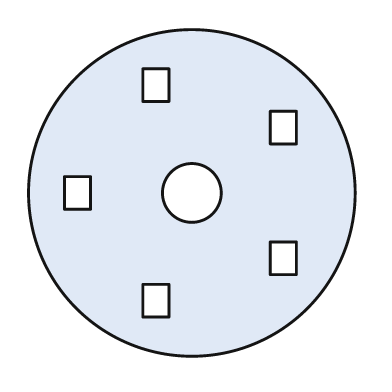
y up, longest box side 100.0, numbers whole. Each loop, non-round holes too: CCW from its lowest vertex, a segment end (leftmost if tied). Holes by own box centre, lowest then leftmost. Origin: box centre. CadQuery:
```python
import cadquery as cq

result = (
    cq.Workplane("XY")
    .moveTo(0.0, 0.0)
    .circle(50.0)
    .moveTo(-15.0, -38.0)
    .lineTo(-7.0, -38.0)
    .lineTo(-7.0, -28.0)
    .lineTo(-15.0, -28.0)
    .close()
    .moveTo(24.0, -25.0)
    .lineTo(32.0, -25.0)
    .lineTo(32.0, -15.0)
    .lineTo(24.0, -15.0)
    .close()
    .moveTo(-39.0, -5.0)
    .lineTo(-31.0, -5.0)
    .lineTo(-31.0, 5.0)
    .lineTo(-39.0, 5.0)
    .close()
    .moveTo(0.0, 0.0)
    .circle(9.0)
    .moveTo(24.0, 15.0)
    .lineTo(32.0, 15.0)
    .lineTo(32.0, 25.0)
    .lineTo(24.0, 25.0)
    .close()
    .moveTo(-15.0, 28.0)
    .lineTo(-7.0, 28.0)
    .lineTo(-7.0, 38.0)
    .lineTo(-15.0, 38.0)
    .close()
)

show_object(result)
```